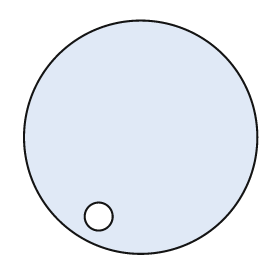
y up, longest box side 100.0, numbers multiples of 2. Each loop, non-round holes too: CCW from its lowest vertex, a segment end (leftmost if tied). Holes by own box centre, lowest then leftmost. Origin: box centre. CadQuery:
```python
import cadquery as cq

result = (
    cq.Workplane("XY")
    .moveTo(0.0, 0.0)
    .circle(50.0)
    .moveTo(-18.0, -34.0)
    .circle(6.0)
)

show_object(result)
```